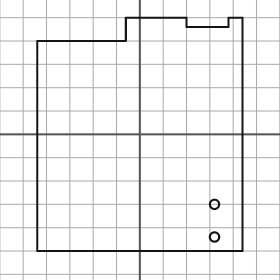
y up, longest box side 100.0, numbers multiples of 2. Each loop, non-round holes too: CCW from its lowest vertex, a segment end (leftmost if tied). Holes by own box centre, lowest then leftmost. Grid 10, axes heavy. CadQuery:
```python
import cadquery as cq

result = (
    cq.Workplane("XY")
    .moveTo(-44.0, -50.0)
    .lineTo(44.0, -50.0)
    .lineTo(44.0, 50.0)
    .lineTo(38.0, 50.0)
    .lineTo(38.0, 46.0)
    .lineTo(20.0, 46.0)
    .lineTo(20.0, 50.0)
    .lineTo(-6.0, 50.0)
    .lineTo(-6.0, 40.0)
    .lineTo(-44.0, 40.0)
    .close()
    .moveTo(32.0, -44.0)
    .circle(2.0)
    .moveTo(32.0, -30.0)
    .circle(2.0)
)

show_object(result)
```